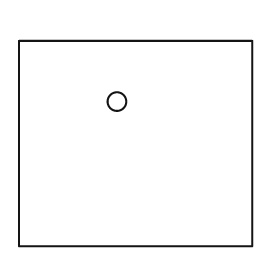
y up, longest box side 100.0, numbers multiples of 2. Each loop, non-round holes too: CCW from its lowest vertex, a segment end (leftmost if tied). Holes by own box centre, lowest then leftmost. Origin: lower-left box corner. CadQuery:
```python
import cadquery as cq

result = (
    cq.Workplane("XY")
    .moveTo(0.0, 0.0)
    .lineTo(100.0, 0.0)
    .lineTo(100.0, 88.0)
    .lineTo(0.0, 88.0)
    .close()
    .moveTo(42.0, 62.0)
    .circle(4.0)
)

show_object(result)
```